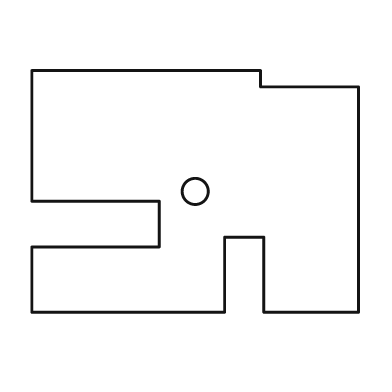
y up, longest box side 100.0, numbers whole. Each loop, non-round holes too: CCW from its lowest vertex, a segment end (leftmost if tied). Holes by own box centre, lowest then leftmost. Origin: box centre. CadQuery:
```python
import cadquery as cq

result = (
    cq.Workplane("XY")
    .moveTo(-50.0, -37.0)
    .lineTo(9.0, -37.0)
    .lineTo(9.0, -14.0)
    .lineTo(21.0, -14.0)
    .lineTo(21.0, -37.0)
    .lineTo(50.0, -37.0)
    .lineTo(50.0, 32.0)
    .lineTo(20.0, 32.0)
    .lineTo(20.0, 37.0)
    .lineTo(-50.0, 37.0)
    .lineTo(-50.0, -3.0)
    .lineTo(-11.0, -3.0)
    .lineTo(-11.0, -17.0)
    .lineTo(-50.0, -17.0)
    .close()
    .moveTo(0.0, 0.0)
    .circle(4.0)
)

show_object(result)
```